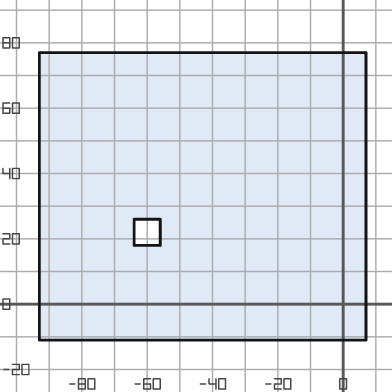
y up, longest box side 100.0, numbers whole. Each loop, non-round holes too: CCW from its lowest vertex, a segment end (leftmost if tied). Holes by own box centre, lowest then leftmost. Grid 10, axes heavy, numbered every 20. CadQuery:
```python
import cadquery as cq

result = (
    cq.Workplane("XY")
    .moveTo(-93.0, -11.0)
    .lineTo(7.0, -11.0)
    .lineTo(7.0, 77.0)
    .lineTo(-93.0, 77.0)
    .close()
    .moveTo(-64.0, 18.0)
    .lineTo(-56.0, 18.0)
    .lineTo(-56.0, 26.0)
    .lineTo(-64.0, 26.0)
    .close()
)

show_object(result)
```